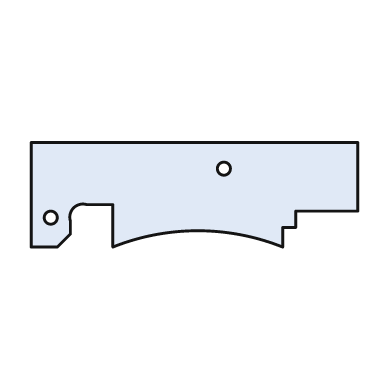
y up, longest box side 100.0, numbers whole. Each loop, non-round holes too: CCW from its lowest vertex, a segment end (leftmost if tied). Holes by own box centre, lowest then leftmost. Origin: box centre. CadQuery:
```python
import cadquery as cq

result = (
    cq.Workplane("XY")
    .moveTo(-50.0, -16.0)
    .lineTo(-42.0, -16.0)
    .lineTo(-38.0, -12.0)
    .lineTo(-38.0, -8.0)
    .threePointArc((-37.0, -4.0), (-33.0, -3.0))
    .lineTo(-25.0, -3.0)
    .lineTo(-25.0, -16.0)
    .threePointArc((1.0, -11.0), (27.0, -16.0))
    .lineTo(27.0, -10.0)
    .lineTo(31.0, -10.0)
    .lineTo(31.0, -5.0)
    .lineTo(50.0, -5.0)
    .lineTo(50.0, 16.0)
    .lineTo(-50.0, 16.0)
    .close()
    .moveTo(-44.0, -7.0)
    .circle(2.0)
    .moveTo(9.0, 8.0)
    .circle(2.0)
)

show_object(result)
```